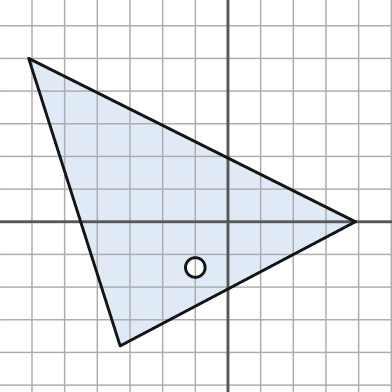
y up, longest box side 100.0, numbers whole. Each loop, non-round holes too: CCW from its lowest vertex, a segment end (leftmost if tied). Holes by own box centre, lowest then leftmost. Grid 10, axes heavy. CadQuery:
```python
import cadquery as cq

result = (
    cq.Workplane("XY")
    .moveTo(-33.0, -38.0)
    .lineTo(39.0, 0.0)
    .lineTo(-61.0, 50.0)
    .close()
    .moveTo(-10.0, -14.0)
    .circle(3.0)
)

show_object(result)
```